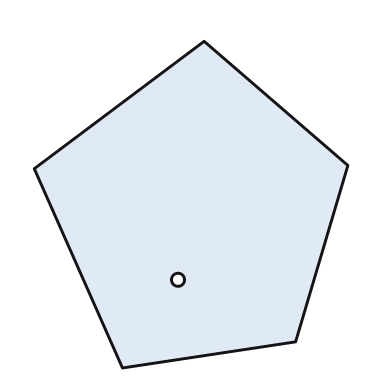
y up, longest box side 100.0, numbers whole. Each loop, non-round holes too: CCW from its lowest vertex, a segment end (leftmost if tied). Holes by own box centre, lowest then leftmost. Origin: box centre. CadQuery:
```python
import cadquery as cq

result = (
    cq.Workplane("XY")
    .moveTo(-21.0, -50.0)
    .lineTo(32.0, -42.0)
    .lineTo(48.0, 12.0)
    .lineTo(4.0, 50.0)
    .lineTo(-48.0, 11.0)
    .close()
    .moveTo(-4.0, -23.0)
    .circle(2.0)
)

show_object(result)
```